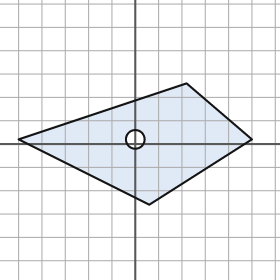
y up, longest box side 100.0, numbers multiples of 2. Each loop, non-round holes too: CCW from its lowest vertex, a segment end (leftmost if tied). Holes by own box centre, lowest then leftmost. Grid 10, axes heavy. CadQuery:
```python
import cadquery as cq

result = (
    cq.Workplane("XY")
    .moveTo(6.0, -26.0)
    .lineTo(50.0, 2.0)
    .lineTo(22.0, 26.0)
    .lineTo(-50.0, 2.0)
    .close()
    .moveTo(0.0, 2.0)
    .circle(4.0)
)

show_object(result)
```